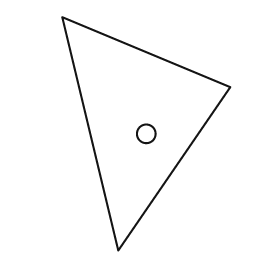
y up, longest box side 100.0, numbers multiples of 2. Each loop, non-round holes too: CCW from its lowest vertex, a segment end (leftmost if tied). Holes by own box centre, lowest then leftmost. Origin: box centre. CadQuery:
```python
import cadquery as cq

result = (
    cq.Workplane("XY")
    .moveTo(-12.0, -50.0)
    .lineTo(36.0, 20.0)
    .lineTo(-36.0, 50.0)
    .close()
    .moveTo(0.0, 0.0)
    .circle(4.0)
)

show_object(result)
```